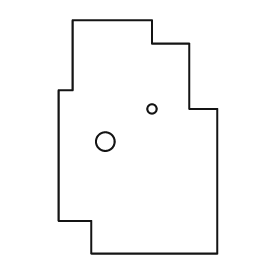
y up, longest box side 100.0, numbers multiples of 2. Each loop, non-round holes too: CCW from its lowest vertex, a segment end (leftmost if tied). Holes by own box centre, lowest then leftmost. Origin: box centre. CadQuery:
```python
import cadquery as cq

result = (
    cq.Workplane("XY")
    .moveTo(-20.0, -50.0)
    .lineTo(34.0, -50.0)
    .lineTo(34.0, 12.0)
    .lineTo(22.0, 12.0)
    .lineTo(22.0, 40.0)
    .lineTo(6.0, 40.0)
    .lineTo(6.0, 50.0)
    .lineTo(-28.0, 50.0)
    .lineTo(-28.0, 20.0)
    .lineTo(-34.0, 20.0)
    .lineTo(-34.0, -36.0)
    .lineTo(-20.0, -36.0)
    .close()
    .moveTo(-14.0, -2.0)
    .circle(4.0)
    .moveTo(6.0, 12.0)
    .circle(2.0)
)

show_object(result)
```